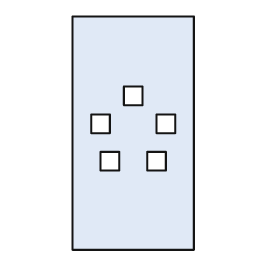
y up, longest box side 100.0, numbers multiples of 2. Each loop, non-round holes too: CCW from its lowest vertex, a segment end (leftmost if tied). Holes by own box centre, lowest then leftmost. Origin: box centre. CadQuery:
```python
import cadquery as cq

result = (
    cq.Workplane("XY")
    .moveTo(-26.0, -50.0)
    .lineTo(26.0, -50.0)
    .lineTo(26.0, 50.0)
    .lineTo(-26.0, 50.0)
    .close()
    .moveTo(-14.0, -16.0)
    .lineTo(-6.0, -16.0)
    .lineTo(-6.0, -8.0)
    .lineTo(-14.0, -8.0)
    .close()
    .moveTo(6.0, -16.0)
    .lineTo(14.0, -16.0)
    .lineTo(14.0, -8.0)
    .lineTo(6.0, -8.0)
    .close()
    .moveTo(-18.0, 0.0)
    .lineTo(-10.0, 0.0)
    .lineTo(-10.0, 8.0)
    .lineTo(-18.0, 8.0)
    .close()
    .moveTo(10.0, 0.0)
    .lineTo(18.0, 0.0)
    .lineTo(18.0, 8.0)
    .lineTo(10.0, 8.0)
    .close()
    .moveTo(-4.0, 12.0)
    .lineTo(4.0, 12.0)
    .lineTo(4.0, 20.0)
    .lineTo(-4.0, 20.0)
    .close()
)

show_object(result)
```